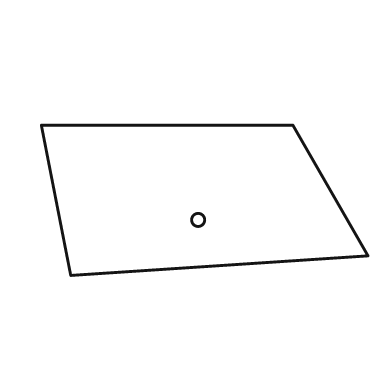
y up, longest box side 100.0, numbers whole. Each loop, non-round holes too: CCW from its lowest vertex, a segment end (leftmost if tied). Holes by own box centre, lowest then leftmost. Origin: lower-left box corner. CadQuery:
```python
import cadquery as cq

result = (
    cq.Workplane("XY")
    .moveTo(9.0, 0.0)
    .lineTo(100.0, 6.0)
    .lineTo(77.0, 46.0)
    .lineTo(0.0, 46.0)
    .close()
    .moveTo(48.0, 17.0)
    .circle(2.0)
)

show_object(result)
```